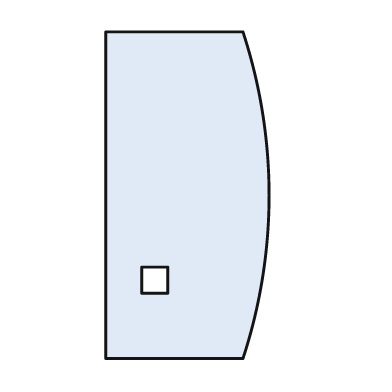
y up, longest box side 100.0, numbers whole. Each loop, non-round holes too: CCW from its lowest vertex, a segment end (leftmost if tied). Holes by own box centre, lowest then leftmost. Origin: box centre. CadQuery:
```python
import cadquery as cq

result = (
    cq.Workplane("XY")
    .moveTo(-25.0, -50.0)
    .lineTo(17.0, -50.0)
    .threePointArc((25.0, 0.0), (17.0, 50.0))
    .lineTo(-25.0, 50.0)
    .close()
    .moveTo(-14.0, -30.0)
    .lineTo(-6.0, -30.0)
    .lineTo(-6.0, -22.0)
    .lineTo(-14.0, -22.0)
    .close()
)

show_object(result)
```